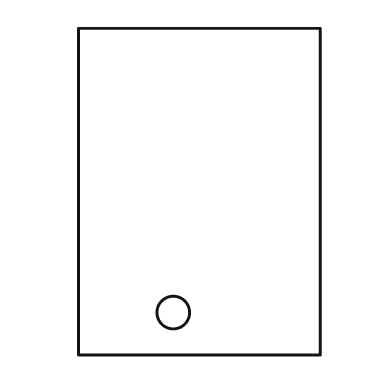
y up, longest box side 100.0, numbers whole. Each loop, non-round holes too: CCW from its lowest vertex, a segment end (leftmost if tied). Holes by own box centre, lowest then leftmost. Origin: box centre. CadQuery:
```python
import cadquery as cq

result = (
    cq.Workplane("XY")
    .moveTo(-37.0, -50.0)
    .lineTo(37.0, -50.0)
    .lineTo(37.0, 50.0)
    .lineTo(-37.0, 50.0)
    .close()
    .moveTo(-8.0, -37.0)
    .circle(5.0)
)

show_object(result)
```